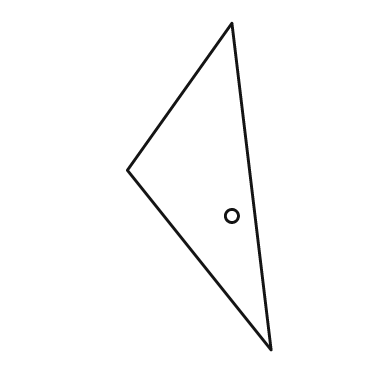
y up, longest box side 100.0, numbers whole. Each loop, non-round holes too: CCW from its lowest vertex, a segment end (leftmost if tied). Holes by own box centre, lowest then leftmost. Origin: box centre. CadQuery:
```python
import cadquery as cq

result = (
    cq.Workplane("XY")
    .moveTo(22.0, -50.0)
    .lineTo(10.0, 50.0)
    .lineTo(-22.0, 5.0)
    .close()
    .moveTo(10.0, -9.0)
    .circle(2.0)
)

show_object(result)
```